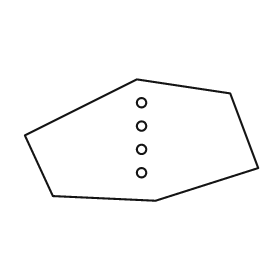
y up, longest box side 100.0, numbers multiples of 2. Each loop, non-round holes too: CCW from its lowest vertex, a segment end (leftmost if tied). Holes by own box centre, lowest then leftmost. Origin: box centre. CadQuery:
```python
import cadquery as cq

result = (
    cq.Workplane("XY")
    .moveTo(6.0, -26.0)
    .lineTo(50.0, -12.0)
    .lineTo(38.0, 20.0)
    .lineTo(-2.0, 26.0)
    .lineTo(-50.0, 2.0)
    .lineTo(-38.0, -24.0)
    .close()
    .moveTo(0.0, -14.0)
    .circle(2.0)
    .moveTo(0.0, -4.0)
    .circle(2.0)
    .moveTo(0.0, 6.0)
    .circle(2.0)
    .moveTo(0.0, 16.0)
    .circle(2.0)
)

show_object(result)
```